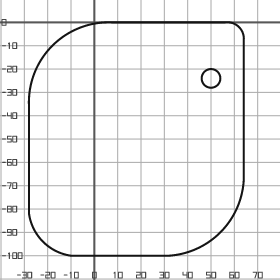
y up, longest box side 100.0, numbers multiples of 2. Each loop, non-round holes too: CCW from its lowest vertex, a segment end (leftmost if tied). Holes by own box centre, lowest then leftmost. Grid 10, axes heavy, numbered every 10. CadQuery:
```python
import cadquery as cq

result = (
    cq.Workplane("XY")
    .moveTo(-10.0, -100.0)
    .lineTo(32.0, -100.0)
    .threePointArc((54.0, -90.0), (64.0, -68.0))
    .lineTo(64.0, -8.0)
    .threePointArc((62.0, -2.0), (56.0, 0.0))
    .lineTo(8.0, 0.0)
    .threePointArc((-18.0, -10.0), (-28.0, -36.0))
    .lineTo(-28.0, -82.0)
    .threePointArc((-22.0, -94.0), (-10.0, -100.0))
    .close()
    .moveTo(50.0, -24.0)
    .circle(4.0)
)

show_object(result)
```